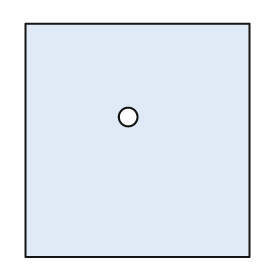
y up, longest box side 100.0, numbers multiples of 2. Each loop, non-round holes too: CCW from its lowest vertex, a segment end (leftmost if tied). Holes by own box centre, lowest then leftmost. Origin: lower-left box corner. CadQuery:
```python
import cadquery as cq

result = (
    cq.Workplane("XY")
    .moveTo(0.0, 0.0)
    .lineTo(96.0, 0.0)
    .lineTo(96.0, 100.0)
    .lineTo(0.0, 100.0)
    .close()
    .moveTo(44.0, 60.0)
    .circle(4.0)
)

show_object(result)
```